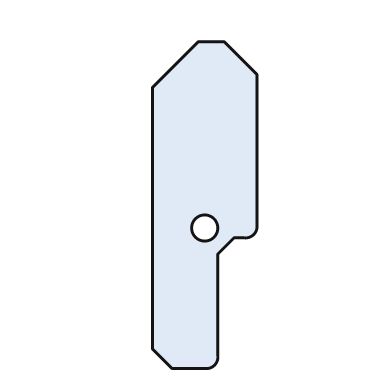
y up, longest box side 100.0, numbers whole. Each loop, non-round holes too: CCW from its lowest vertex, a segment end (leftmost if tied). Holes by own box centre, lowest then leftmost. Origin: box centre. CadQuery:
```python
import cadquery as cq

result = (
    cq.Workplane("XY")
    .moveTo(-10.0, -50.0)
    .lineTo(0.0, -50.0)
    .threePointArc((3.0, -49.0), (4.0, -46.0))
    .lineTo(4.0, -15.0)
    .lineTo(9.0, -10.0)
    .lineTo(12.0, -10.0)
    .threePointArc((15.0, -9.0), (16.0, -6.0))
    .lineTo(16.0, 40.0)
    .lineTo(6.0, 50.0)
    .lineTo(-2.0, 50.0)
    .lineTo(-16.0, 36.0)
    .lineTo(-16.0, -44.0)
    .close()
    .moveTo(0.0, -7.0)
    .circle(4.0)
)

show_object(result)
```